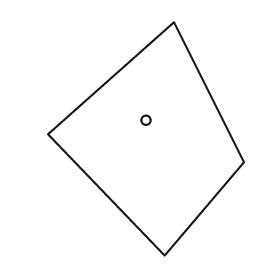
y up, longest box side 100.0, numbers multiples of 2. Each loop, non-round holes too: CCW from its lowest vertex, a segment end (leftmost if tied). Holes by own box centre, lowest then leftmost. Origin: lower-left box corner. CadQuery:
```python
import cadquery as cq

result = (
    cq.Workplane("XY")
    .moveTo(50.0, 0.0)
    .lineTo(84.0, 40.0)
    .lineTo(54.0, 100.0)
    .lineTo(0.0, 52.0)
    .close()
    .moveTo(42.0, 58.0)
    .circle(2.0)
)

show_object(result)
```